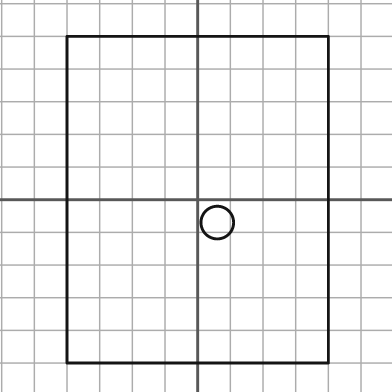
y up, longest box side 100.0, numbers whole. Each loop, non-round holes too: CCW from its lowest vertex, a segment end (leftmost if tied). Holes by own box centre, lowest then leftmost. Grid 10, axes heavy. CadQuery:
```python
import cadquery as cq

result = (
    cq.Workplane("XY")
    .moveTo(-40.0, -50.0)
    .lineTo(40.0, -50.0)
    .lineTo(40.0, 50.0)
    .lineTo(-40.0, 50.0)
    .close()
    .moveTo(6.0, -7.0)
    .circle(5.0)
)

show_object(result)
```